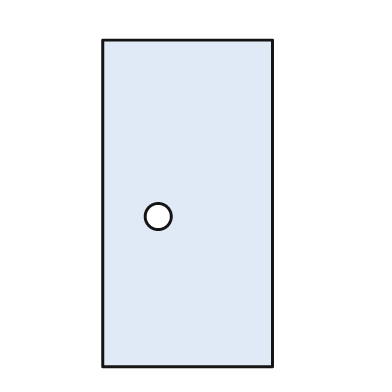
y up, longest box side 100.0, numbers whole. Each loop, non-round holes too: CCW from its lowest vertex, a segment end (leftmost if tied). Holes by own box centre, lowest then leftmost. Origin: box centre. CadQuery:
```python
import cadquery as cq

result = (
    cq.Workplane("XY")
    .moveTo(-26.0, -50.0)
    .lineTo(26.0, -50.0)
    .lineTo(26.0, 50.0)
    .lineTo(-26.0, 50.0)
    .close()
    .moveTo(-9.0, -4.0)
    .circle(4.0)
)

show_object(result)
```